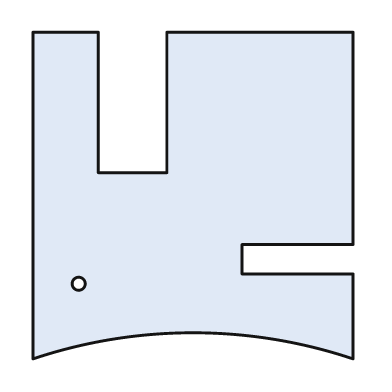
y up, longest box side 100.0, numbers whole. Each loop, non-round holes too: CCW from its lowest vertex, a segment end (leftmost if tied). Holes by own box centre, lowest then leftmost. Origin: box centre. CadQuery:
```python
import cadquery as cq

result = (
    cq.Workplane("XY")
    .moveTo(-49.0, -50.0)
    .threePointArc((0.0, -42.0), (49.0, -50.0))
    .lineTo(49.0, -24.0)
    .lineTo(15.0, -24.0)
    .lineTo(15.0, -15.0)
    .lineTo(49.0, -15.0)
    .lineTo(49.0, 50.0)
    .lineTo(-8.0, 50.0)
    .lineTo(-8.0, 7.0)
    .lineTo(-29.0, 7.0)
    .lineTo(-29.0, 50.0)
    .lineTo(-49.0, 50.0)
    .close()
    .moveTo(-35.0, -27.0)
    .circle(2.0)
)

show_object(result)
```